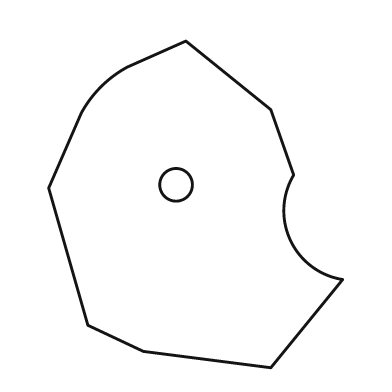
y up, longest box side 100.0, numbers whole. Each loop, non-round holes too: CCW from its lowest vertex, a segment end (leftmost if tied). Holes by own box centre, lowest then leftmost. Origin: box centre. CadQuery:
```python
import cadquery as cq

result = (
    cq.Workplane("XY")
    .moveTo(23.0, -50.0)
    .lineTo(45.0, -23.0)
    .threePointArc((29.0, -11.0), (30.0, 9.0))
    .lineTo(23.0, 29.0)
    .lineTo(-3.0, 50.0)
    .lineTo(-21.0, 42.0)
    .threePointArc((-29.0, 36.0), (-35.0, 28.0))
    .lineTo(-45.0, 5.0)
    .lineTo(-33.0, -37.0)
    .lineTo(-16.0, -45.0)
    .close()
    .moveTo(-6.0, 6.0)
    .circle(5.0)
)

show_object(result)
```